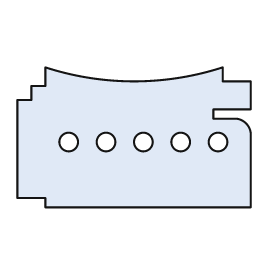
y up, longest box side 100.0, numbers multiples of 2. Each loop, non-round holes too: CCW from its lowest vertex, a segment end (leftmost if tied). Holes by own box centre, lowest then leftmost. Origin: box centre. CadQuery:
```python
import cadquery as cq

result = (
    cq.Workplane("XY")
    .moveTo(-38.0, -30.0)
    .lineTo(50.0, -30.0)
    .lineTo(50.0, 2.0)
    .threePointArc((48.0, 6.0), (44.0, 8.0))
    .lineTo(34.0, 8.0)
    .lineTo(34.0, 12.0)
    .lineTo(50.0, 12.0)
    .lineTo(50.0, 24.0)
    .lineTo(38.0, 24.0)
    .lineTo(38.0, 30.0)
    .threePointArc((0.0, 24.0), (-38.0, 30.0))
    .lineTo(-38.0, 22.0)
    .lineTo(-44.0, 22.0)
    .lineTo(-44.0, 16.0)
    .lineTo(-50.0, 16.0)
    .lineTo(-50.0, -26.0)
    .lineTo(-38.0, -26.0)
    .close()
    .moveTo(-28.0, -2.0)
    .circle(4.0)
    .moveTo(-12.0, -2.0)
    .circle(4.0)
    .moveTo(4.0, -2.0)
    .circle(4.0)
    .moveTo(20.0, -2.0)
    .circle(4.0)
    .moveTo(36.0, -2.0)
    .circle(4.0)
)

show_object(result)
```